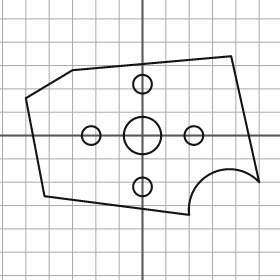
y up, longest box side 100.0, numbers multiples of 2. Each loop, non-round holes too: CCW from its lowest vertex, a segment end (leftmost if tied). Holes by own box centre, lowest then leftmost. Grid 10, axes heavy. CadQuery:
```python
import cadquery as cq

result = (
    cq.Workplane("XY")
    .moveTo(20.0, -34.0)
    .threePointArc((30.0, -16.0), (50.0, -20.0))
    .lineTo(38.0, 34.0)
    .lineTo(-30.0, 28.0)
    .lineTo(-50.0, 16.0)
    .lineTo(-42.0, -26.0)
    .close()
    .moveTo(0.0, -22.0)
    .circle(4.0)
    .moveTo(-22.0, 0.0)
    .circle(4.0)
    .moveTo(0.0, 0.0)
    .circle(8.0)
    .moveTo(22.0, 0.0)
    .circle(4.0)
    .moveTo(0.0, 22.0)
    .circle(4.0)
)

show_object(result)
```